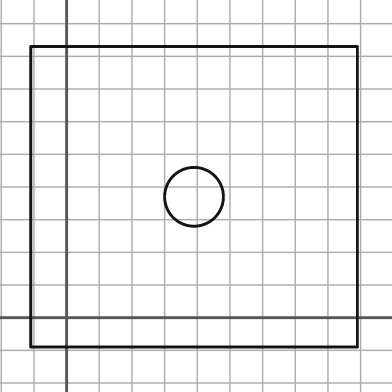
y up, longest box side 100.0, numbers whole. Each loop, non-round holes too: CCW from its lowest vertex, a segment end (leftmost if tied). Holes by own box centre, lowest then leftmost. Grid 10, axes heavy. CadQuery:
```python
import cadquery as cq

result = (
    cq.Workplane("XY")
    .moveTo(-11.0, -9.0)
    .lineTo(89.0, -9.0)
    .lineTo(89.0, 83.0)
    .lineTo(-11.0, 83.0)
    .close()
    .moveTo(39.0, 37.0)
    .circle(9.0)
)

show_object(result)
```